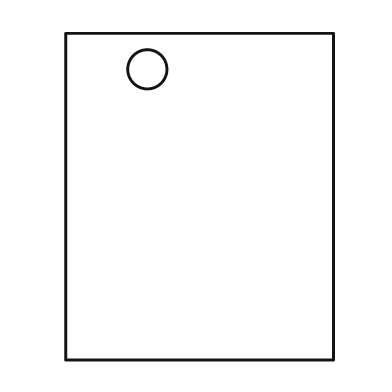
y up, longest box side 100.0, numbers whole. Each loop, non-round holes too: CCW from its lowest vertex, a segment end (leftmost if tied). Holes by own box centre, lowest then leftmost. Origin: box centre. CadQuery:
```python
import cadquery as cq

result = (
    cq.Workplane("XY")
    .moveTo(-41.0, -50.0)
    .lineTo(41.0, -50.0)
    .lineTo(41.0, 50.0)
    .lineTo(-41.0, 50.0)
    .close()
    .moveTo(-16.0, 39.0)
    .circle(6.0)
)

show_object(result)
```